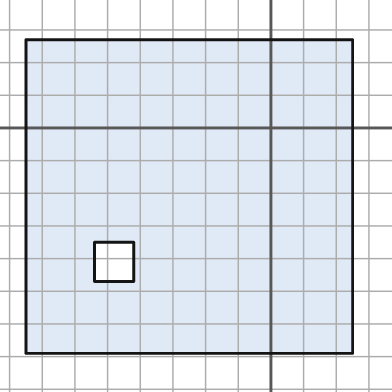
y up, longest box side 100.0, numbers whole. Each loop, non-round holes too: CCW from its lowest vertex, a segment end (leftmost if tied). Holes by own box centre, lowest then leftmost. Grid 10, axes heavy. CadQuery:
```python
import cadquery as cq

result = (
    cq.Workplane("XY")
    .moveTo(-75.0, -69.0)
    .lineTo(25.0, -69.0)
    .lineTo(25.0, 27.0)
    .lineTo(-75.0, 27.0)
    .close()
    .moveTo(-54.0, -47.0)
    .lineTo(-42.0, -47.0)
    .lineTo(-42.0, -35.0)
    .lineTo(-54.0, -35.0)
    .close()
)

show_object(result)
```